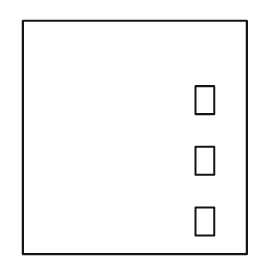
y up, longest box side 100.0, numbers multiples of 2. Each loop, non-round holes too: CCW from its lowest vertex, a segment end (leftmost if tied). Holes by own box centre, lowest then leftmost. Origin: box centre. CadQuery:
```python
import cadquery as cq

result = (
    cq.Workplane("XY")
    .moveTo(-48.0, -50.0)
    .lineTo(48.0, -50.0)
    .lineTo(48.0, 50.0)
    .lineTo(-48.0, 50.0)
    .close()
    .moveTo(26.0, -42.0)
    .lineTo(34.0, -42.0)
    .lineTo(34.0, -30.0)
    .lineTo(26.0, -30.0)
    .close()
    .moveTo(26.0, -16.0)
    .lineTo(34.0, -16.0)
    .lineTo(34.0, -4.0)
    .lineTo(26.0, -4.0)
    .close()
    .moveTo(26.0, 10.0)
    .lineTo(34.0, 10.0)
    .lineTo(34.0, 22.0)
    .lineTo(26.0, 22.0)
    .close()
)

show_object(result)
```